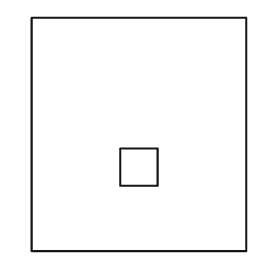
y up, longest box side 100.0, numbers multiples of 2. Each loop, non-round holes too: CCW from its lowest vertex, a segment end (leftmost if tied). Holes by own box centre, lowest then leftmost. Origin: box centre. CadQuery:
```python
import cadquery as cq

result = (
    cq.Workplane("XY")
    .moveTo(-46.0, -50.0)
    .lineTo(46.0, -50.0)
    .lineTo(46.0, 50.0)
    .lineTo(-46.0, 50.0)
    .close()
    .moveTo(-8.0, -22.0)
    .lineTo(8.0, -22.0)
    .lineTo(8.0, -6.0)
    .lineTo(-8.0, -6.0)
    .close()
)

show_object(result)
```